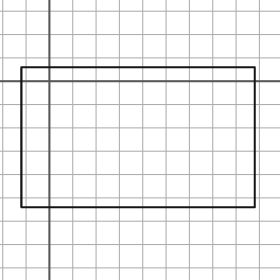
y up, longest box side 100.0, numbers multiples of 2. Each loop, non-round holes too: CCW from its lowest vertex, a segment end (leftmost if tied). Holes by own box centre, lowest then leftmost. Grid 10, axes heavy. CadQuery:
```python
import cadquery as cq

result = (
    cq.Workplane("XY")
    .moveTo(-12.0, -54.0)
    .lineTo(88.0, -54.0)
    .lineTo(88.0, 6.0)
    .lineTo(-12.0, 6.0)
    .close()
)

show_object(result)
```